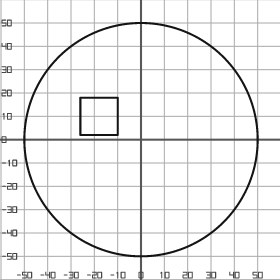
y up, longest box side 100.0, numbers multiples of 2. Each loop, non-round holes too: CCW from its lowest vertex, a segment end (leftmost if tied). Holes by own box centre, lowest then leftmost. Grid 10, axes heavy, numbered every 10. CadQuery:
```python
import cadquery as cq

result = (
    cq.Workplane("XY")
    .moveTo(0.0, 0.0)
    .circle(50.0)
    .moveTo(-26.0, 2.0)
    .lineTo(-10.0, 2.0)
    .lineTo(-10.0, 18.0)
    .lineTo(-26.0, 18.0)
    .close()
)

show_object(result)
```